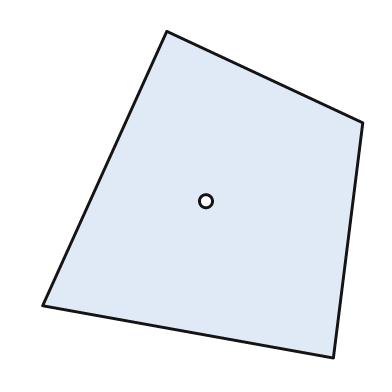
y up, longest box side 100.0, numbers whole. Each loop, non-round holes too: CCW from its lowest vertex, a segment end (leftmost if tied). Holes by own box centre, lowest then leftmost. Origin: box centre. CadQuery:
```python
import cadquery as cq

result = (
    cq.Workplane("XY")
    .moveTo(40.0, -50.0)
    .lineTo(49.0, 22.0)
    .lineTo(-11.0, 50.0)
    .lineTo(-49.0, -34.0)
    .close()
    .moveTo(1.0, -2.0)
    .circle(2.0)
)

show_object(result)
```